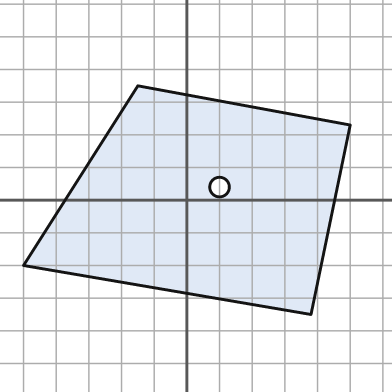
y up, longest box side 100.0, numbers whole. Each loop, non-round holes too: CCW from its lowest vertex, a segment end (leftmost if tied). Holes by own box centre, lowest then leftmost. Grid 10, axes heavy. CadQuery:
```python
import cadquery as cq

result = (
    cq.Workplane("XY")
    .moveTo(38.0, -35.0)
    .lineTo(50.0, 23.0)
    .lineTo(-15.0, 35.0)
    .lineTo(-50.0, -20.0)
    .close()
    .moveTo(10.0, 4.0)
    .circle(3.0)
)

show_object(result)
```